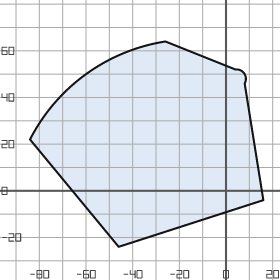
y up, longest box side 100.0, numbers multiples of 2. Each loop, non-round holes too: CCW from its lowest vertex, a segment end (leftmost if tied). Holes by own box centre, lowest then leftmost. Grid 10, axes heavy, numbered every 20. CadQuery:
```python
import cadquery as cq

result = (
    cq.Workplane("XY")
    .moveTo(-46.0, -24.0)
    .lineTo(16.0, -4.0)
    .lineTo(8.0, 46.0)
    .threePointArc((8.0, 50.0), (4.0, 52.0))
    .lineTo(-26.0, 64.0)
    .threePointArc((-60.0, 50.0), (-84.0, 22.0))
    .close()
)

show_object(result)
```